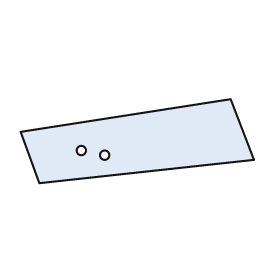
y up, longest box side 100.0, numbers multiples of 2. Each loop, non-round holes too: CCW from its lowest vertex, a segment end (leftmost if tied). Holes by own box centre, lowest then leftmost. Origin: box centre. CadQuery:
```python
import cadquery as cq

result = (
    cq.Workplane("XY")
    .moveTo(-42.0, -18.0)
    .lineTo(50.0, -8.0)
    .lineTo(40.0, 18.0)
    .lineTo(-50.0, 4.0)
    .close()
    .moveTo(-14.0, -6.0)
    .circle(2.0)
    .moveTo(-24.0, -4.0)
    .circle(2.0)
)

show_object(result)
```